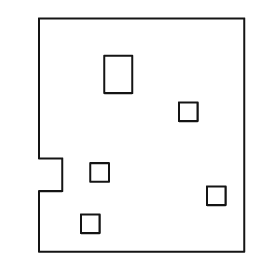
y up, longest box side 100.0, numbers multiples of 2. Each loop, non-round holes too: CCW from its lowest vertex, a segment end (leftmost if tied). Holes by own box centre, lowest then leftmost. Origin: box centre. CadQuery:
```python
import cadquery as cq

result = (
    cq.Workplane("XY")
    .moveTo(-44.0, -50.0)
    .lineTo(44.0, -50.0)
    .lineTo(44.0, 50.0)
    .lineTo(-44.0, 50.0)
    .lineTo(-44.0, -10.0)
    .lineTo(-34.0, -10.0)
    .lineTo(-34.0, -24.0)
    .lineTo(-44.0, -24.0)
    .close()
    .moveTo(-26.0, -42.0)
    .lineTo(-18.0, -42.0)
    .lineTo(-18.0, -34.0)
    .lineTo(-26.0, -34.0)
    .close()
    .moveTo(28.0, -30.0)
    .lineTo(36.0, -30.0)
    .lineTo(36.0, -22.0)
    .lineTo(28.0, -22.0)
    .close()
    .moveTo(-22.0, -20.0)
    .lineTo(-14.0, -20.0)
    .lineTo(-14.0, -12.0)
    .lineTo(-22.0, -12.0)
    .close()
    .moveTo(16.0, 6.0)
    .lineTo(24.0, 6.0)
    .lineTo(24.0, 14.0)
    .lineTo(16.0, 14.0)
    .close()
    .moveTo(-16.0, 18.0)
    .lineTo(-4.0, 18.0)
    .lineTo(-4.0, 34.0)
    .lineTo(-16.0, 34.0)
    .close()
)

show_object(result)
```